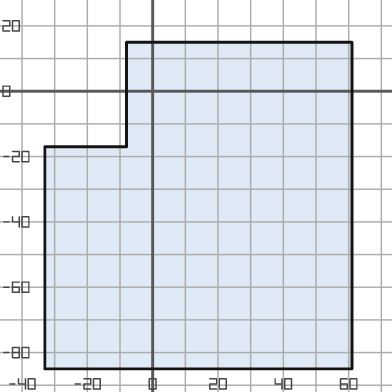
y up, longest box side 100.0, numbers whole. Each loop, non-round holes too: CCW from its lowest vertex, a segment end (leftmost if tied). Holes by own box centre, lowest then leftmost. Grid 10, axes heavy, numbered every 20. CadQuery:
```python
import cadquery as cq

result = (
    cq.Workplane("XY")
    .moveTo(-33.0, -85.0)
    .lineTo(61.0, -85.0)
    .lineTo(61.0, 15.0)
    .lineTo(-8.0, 15.0)
    .lineTo(-8.0, -17.0)
    .lineTo(-33.0, -17.0)
    .close()
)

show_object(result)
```